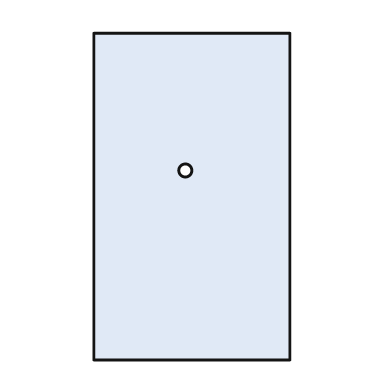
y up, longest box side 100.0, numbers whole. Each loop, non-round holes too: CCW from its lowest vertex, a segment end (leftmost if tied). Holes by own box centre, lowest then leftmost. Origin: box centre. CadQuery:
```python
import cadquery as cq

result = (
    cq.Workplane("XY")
    .moveTo(-30.0, -50.0)
    .lineTo(30.0, -50.0)
    .lineTo(30.0, 50.0)
    .lineTo(-30.0, 50.0)
    .close()
    .moveTo(-2.0, 8.0)
    .circle(2.0)
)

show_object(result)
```